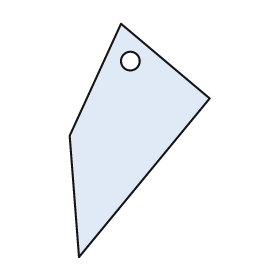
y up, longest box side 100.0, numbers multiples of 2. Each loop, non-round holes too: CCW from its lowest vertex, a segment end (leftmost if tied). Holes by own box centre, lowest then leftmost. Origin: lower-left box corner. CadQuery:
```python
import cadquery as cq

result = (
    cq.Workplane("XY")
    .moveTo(4.0, 0.0)
    .lineTo(60.0, 68.0)
    .lineTo(22.0, 100.0)
    .lineTo(0.0, 52.0)
    .close()
    .moveTo(26.0, 84.0)
    .circle(4.0)
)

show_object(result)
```